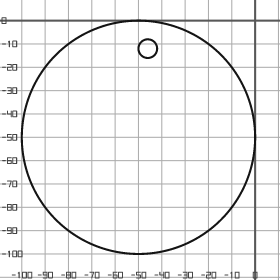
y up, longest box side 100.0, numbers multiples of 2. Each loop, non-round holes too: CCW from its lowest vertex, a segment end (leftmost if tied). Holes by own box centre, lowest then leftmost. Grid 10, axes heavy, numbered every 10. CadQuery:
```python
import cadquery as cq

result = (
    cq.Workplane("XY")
    .moveTo(-50.0, -50.0)
    .circle(50.0)
    .moveTo(-46.0, -12.0)
    .circle(4.0)
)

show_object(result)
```